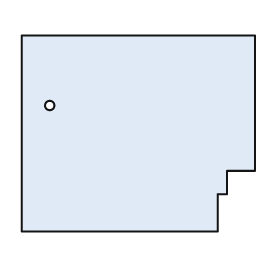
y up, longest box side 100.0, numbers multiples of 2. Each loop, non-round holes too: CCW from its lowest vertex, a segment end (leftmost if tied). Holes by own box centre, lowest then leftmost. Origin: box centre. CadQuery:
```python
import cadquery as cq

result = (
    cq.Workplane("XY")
    .moveTo(-50.0, -42.0)
    .lineTo(34.0, -42.0)
    .lineTo(34.0, -26.0)
    .lineTo(38.0, -26.0)
    .lineTo(38.0, -16.0)
    .lineTo(50.0, -16.0)
    .lineTo(50.0, 42.0)
    .lineTo(-50.0, 42.0)
    .close()
    .moveTo(-38.0, 12.0)
    .circle(2.0)
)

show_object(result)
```